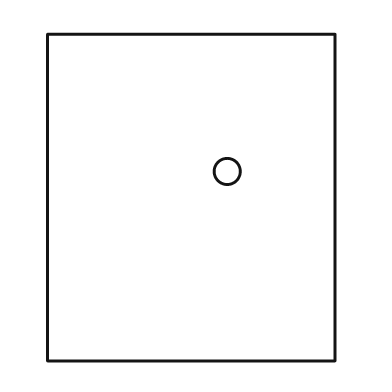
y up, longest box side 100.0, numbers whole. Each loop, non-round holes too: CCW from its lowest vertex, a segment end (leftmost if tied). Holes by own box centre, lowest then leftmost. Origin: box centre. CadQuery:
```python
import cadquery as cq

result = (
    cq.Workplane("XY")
    .moveTo(-44.0, -50.0)
    .lineTo(44.0, -50.0)
    .lineTo(44.0, 50.0)
    .lineTo(-44.0, 50.0)
    .close()
    .moveTo(11.0, 8.0)
    .circle(4.0)
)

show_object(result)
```